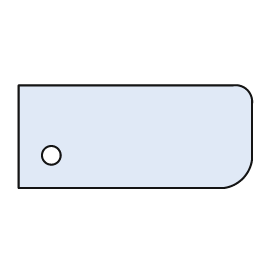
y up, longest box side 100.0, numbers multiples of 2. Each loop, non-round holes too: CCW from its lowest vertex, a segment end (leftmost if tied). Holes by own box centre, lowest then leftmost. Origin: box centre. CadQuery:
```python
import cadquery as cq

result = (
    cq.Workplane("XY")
    .moveTo(-50.0, -22.0)
    .lineTo(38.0, -22.0)
    .threePointArc((46.0, -18.0), (50.0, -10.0))
    .lineTo(50.0, 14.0)
    .threePointArc((48.0, 20.0), (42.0, 22.0))
    .lineTo(-50.0, 22.0)
    .close()
    .moveTo(-36.0, -8.0)
    .circle(4.0)
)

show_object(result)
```